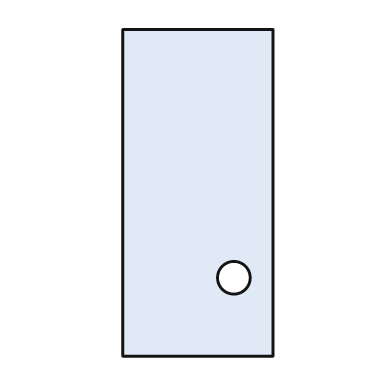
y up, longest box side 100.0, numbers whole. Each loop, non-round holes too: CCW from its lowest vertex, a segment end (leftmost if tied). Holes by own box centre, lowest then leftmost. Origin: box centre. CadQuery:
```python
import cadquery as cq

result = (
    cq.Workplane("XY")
    .moveTo(-23.0, -50.0)
    .lineTo(23.0, -50.0)
    .lineTo(23.0, 50.0)
    .lineTo(-23.0, 50.0)
    .close()
    .moveTo(11.0, -26.0)
    .circle(5.0)
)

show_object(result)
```